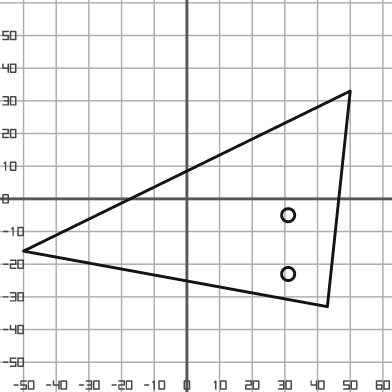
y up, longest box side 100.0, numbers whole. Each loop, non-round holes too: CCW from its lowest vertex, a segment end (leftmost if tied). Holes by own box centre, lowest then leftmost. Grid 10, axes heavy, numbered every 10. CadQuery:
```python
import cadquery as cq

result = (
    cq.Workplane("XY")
    .moveTo(43.0, -33.0)
    .lineTo(50.0, 33.0)
    .lineTo(-50.0, -16.0)
    .close()
    .moveTo(31.0, -23.0)
    .circle(2.0)
    .moveTo(31.0, -5.0)
    .circle(2.0)
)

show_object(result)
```